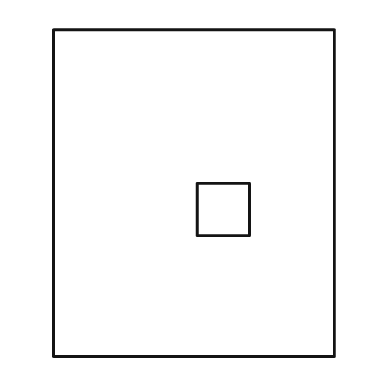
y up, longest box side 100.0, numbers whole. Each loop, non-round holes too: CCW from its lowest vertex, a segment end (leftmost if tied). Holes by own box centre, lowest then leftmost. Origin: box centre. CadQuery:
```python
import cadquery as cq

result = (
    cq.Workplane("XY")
    .moveTo(-43.0, -50.0)
    .lineTo(43.0, -50.0)
    .lineTo(43.0, 50.0)
    .lineTo(-43.0, 50.0)
    .close()
    .moveTo(1.0, -13.0)
    .lineTo(17.0, -13.0)
    .lineTo(17.0, 3.0)
    .lineTo(1.0, 3.0)
    .close()
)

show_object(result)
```